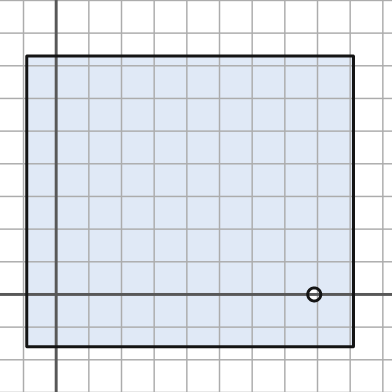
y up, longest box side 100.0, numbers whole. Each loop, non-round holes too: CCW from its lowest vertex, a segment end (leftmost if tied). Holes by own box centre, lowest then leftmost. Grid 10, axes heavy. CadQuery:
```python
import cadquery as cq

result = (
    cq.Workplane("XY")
    .moveTo(-9.0, -16.0)
    .lineTo(91.0, -16.0)
    .lineTo(91.0, 73.0)
    .lineTo(-9.0, 73.0)
    .close()
    .moveTo(79.0, 0.0)
    .circle(2.0)
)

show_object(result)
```